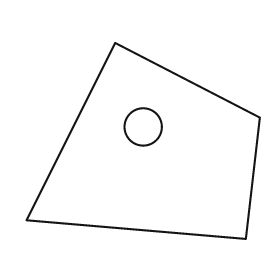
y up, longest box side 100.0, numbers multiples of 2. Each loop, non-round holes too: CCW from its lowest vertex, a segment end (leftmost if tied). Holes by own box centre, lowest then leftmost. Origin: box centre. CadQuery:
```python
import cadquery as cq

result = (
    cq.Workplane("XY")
    .moveTo(44.0, -42.0)
    .lineTo(50.0, 10.0)
    .lineTo(-12.0, 42.0)
    .lineTo(-50.0, -34.0)
    .close()
    .moveTo(0.0, 6.0)
    .circle(8.0)
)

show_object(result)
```